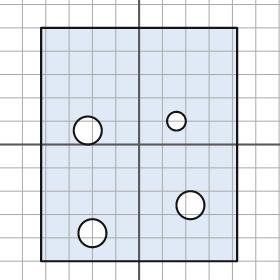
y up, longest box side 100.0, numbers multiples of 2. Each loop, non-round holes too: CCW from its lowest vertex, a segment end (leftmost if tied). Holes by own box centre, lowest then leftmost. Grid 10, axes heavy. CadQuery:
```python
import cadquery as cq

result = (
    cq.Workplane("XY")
    .moveTo(-42.0, -50.0)
    .lineTo(42.0, -50.0)
    .lineTo(42.0, 50.0)
    .lineTo(-42.0, 50.0)
    .close()
    .moveTo(-20.0, -38.0)
    .circle(6.0)
    .moveTo(22.0, -26.0)
    .circle(6.0)
    .moveTo(-22.0, 6.0)
    .circle(6.0)
    .moveTo(16.0, 10.0)
    .circle(4.0)
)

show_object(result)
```